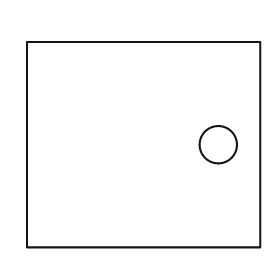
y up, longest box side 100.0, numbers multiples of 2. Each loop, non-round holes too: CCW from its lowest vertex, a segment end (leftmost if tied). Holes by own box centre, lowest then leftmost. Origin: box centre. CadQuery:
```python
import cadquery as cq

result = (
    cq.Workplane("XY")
    .moveTo(-50.0, -44.0)
    .lineTo(50.0, -44.0)
    .lineTo(50.0, 44.0)
    .lineTo(-50.0, 44.0)
    .close()
    .moveTo(32.0, 0.0)
    .circle(8.0)
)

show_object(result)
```